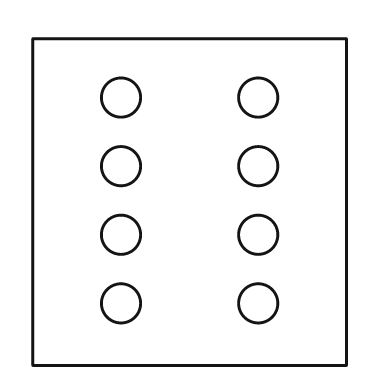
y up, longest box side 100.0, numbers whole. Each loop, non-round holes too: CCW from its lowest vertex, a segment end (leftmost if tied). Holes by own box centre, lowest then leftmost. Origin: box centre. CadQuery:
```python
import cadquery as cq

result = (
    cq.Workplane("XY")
    .moveTo(-48.0, -50.0)
    .lineTo(48.0, -50.0)
    .lineTo(48.0, 50.0)
    .lineTo(-48.0, 50.0)
    .close()
    .moveTo(-21.0, -31.0)
    .circle(6.0)
    .moveTo(21.0, -31.0)
    .circle(6.0)
    .moveTo(-21.0, -10.0)
    .circle(6.0)
    .moveTo(21.0, -10.0)
    .circle(6.0)
    .moveTo(-21.0, 11.0)
    .circle(6.0)
    .moveTo(21.0, 11.0)
    .circle(6.0)
    .moveTo(-21.0, 32.0)
    .circle(6.0)
    .moveTo(21.0, 32.0)
    .circle(6.0)
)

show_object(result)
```